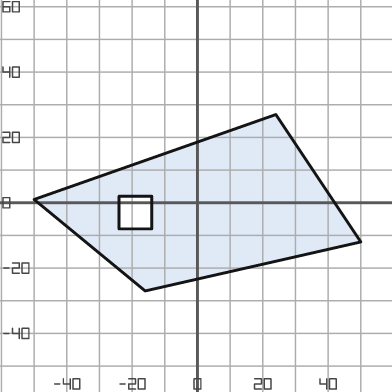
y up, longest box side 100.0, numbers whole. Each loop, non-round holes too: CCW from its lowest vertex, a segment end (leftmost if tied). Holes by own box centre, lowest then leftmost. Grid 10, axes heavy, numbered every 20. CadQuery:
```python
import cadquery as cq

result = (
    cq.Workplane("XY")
    .moveTo(-16.0, -27.0)
    .lineTo(50.0, -12.0)
    .lineTo(24.0, 27.0)
    .lineTo(-50.0, 1.0)
    .close()
    .moveTo(-24.0, -8.0)
    .lineTo(-14.0, -8.0)
    .lineTo(-14.0, 2.0)
    .lineTo(-24.0, 2.0)
    .close()
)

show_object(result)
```